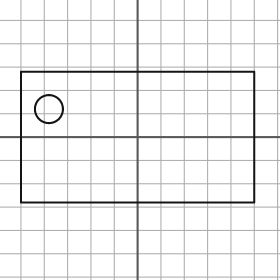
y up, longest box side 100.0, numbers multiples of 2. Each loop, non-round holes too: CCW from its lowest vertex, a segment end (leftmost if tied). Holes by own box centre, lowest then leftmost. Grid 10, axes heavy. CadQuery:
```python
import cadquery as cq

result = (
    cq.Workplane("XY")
    .moveTo(-50.0, -28.0)
    .lineTo(50.0, -28.0)
    .lineTo(50.0, 28.0)
    .lineTo(-50.0, 28.0)
    .close()
    .moveTo(-38.0, 12.0)
    .circle(6.0)
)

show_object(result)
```